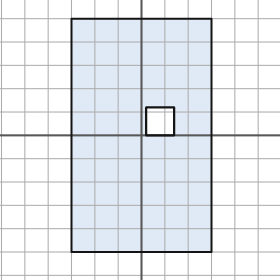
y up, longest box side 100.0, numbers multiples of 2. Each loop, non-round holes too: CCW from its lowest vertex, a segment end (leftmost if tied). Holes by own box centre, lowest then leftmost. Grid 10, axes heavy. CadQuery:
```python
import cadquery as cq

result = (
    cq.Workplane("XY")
    .moveTo(-30.0, -50.0)
    .lineTo(30.0, -50.0)
    .lineTo(30.0, 50.0)
    .lineTo(-30.0, 50.0)
    .close()
    .moveTo(2.0, 0.0)
    .lineTo(14.0, 0.0)
    .lineTo(14.0, 12.0)
    .lineTo(2.0, 12.0)
    .close()
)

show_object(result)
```